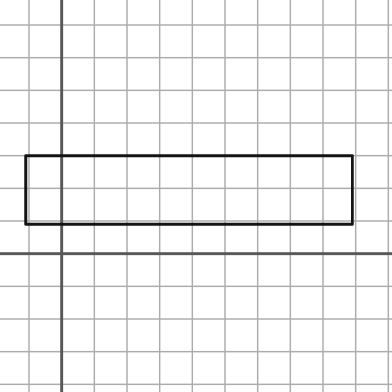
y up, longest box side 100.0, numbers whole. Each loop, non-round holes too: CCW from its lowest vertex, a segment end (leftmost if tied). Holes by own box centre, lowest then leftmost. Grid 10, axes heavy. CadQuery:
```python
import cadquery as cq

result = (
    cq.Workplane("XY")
    .moveTo(-11.0, 9.0)
    .lineTo(89.0, 9.0)
    .lineTo(89.0, 30.0)
    .lineTo(-11.0, 30.0)
    .close()
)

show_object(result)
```